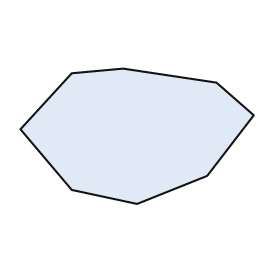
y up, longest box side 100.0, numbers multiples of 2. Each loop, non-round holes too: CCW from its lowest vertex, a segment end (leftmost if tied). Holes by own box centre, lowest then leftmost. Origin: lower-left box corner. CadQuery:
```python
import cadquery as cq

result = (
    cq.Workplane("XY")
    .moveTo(50.0, 0.0)
    .lineTo(80.0, 12.0)
    .lineTo(100.0, 38.0)
    .lineTo(84.0, 52.0)
    .lineTo(44.0, 58.0)
    .lineTo(22.0, 56.0)
    .lineTo(0.0, 32.0)
    .lineTo(22.0, 6.0)
    .close()
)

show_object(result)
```